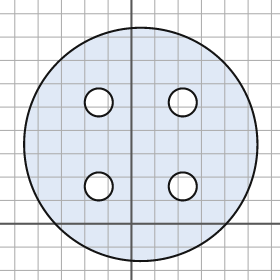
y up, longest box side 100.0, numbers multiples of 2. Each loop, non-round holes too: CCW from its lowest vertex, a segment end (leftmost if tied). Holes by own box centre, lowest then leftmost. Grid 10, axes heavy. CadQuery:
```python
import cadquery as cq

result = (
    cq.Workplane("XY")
    .moveTo(4.0, 34.0)
    .circle(50.0)
    .moveTo(-14.0, 16.0)
    .circle(6.0)
    .moveTo(22.0, 16.0)
    .circle(6.0)
    .moveTo(-14.0, 52.0)
    .circle(6.0)
    .moveTo(22.0, 52.0)
    .circle(6.0)
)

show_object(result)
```